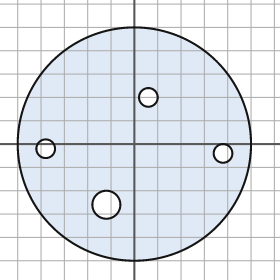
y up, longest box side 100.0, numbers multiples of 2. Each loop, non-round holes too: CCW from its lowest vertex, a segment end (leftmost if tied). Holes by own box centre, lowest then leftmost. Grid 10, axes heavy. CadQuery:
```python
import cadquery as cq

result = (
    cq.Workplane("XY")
    .moveTo(0.0, 0.0)
    .circle(50.0)
    .moveTo(-12.0, -26.0)
    .circle(6.0)
    .moveTo(38.0, -4.0)
    .circle(4.0)
    .moveTo(-38.0, -2.0)
    .circle(4.0)
    .moveTo(6.0, 20.0)
    .circle(4.0)
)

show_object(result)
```